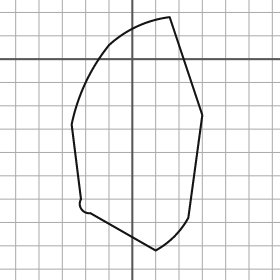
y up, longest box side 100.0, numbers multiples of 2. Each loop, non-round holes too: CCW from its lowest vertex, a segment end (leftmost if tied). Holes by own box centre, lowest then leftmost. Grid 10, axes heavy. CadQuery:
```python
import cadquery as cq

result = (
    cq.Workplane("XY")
    .moveTo(10.0, -82.0)
    .threePointArc((18.0, -76.0), (24.0, -68.0))
    .lineTo(30.0, -24.0)
    .lineTo(16.0, 18.0)
    .threePointArc((2.0, 14.0), (-10.0, 6.0))
    .threePointArc((-20.0, -10.0), (-26.0, -28.0))
    .lineTo(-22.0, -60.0)
    .threePointArc((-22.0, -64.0), (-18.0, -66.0))
    .close()
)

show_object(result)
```